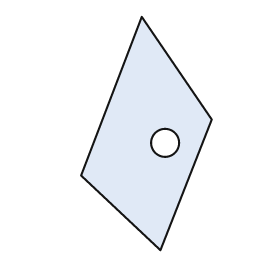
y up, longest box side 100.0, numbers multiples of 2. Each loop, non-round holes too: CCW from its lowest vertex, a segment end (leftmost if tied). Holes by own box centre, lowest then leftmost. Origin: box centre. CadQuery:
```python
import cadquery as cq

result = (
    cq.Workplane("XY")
    .moveTo(6.0, -50.0)
    .lineTo(28.0, 6.0)
    .lineTo(-2.0, 50.0)
    .lineTo(-28.0, -18.0)
    .close()
    .moveTo(8.0, -4.0)
    .circle(6.0)
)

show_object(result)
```